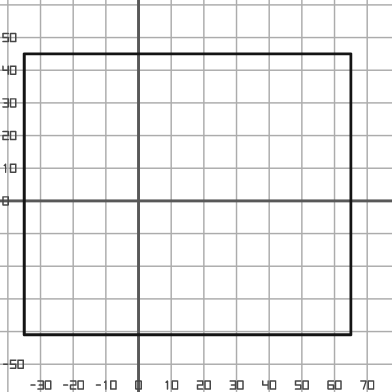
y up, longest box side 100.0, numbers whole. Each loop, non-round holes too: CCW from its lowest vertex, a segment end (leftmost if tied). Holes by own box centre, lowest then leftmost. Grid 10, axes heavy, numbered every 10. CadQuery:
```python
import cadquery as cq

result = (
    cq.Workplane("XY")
    .moveTo(-35.0, -41.0)
    .lineTo(65.0, -41.0)
    .lineTo(65.0, 45.0)
    .lineTo(-35.0, 45.0)
    .close()
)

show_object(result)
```